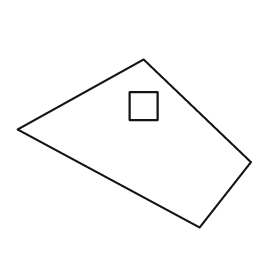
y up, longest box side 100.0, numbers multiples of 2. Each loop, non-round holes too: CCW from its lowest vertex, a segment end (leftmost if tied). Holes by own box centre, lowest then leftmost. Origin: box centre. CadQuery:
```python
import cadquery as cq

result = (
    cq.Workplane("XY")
    .moveTo(28.0, -36.0)
    .lineTo(50.0, -8.0)
    .lineTo(4.0, 36.0)
    .lineTo(-50.0, 6.0)
    .close()
    .moveTo(-2.0, 10.0)
    .lineTo(10.0, 10.0)
    .lineTo(10.0, 22.0)
    .lineTo(-2.0, 22.0)
    .close()
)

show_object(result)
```